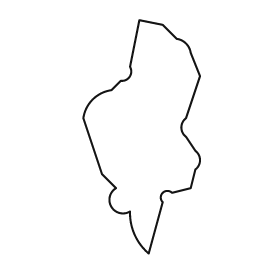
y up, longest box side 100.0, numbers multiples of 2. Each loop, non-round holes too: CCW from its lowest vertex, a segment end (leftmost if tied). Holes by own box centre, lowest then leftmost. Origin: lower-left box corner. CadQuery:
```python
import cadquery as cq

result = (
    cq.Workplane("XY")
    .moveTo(28.0, 0.0)
    .lineTo(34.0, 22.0)
    .threePointArc((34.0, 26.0), (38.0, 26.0))
    .lineTo(46.0, 28.0)
    .lineTo(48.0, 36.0)
    .threePointArc((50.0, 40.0), (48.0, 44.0))
    .lineTo(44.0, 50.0)
    .threePointArc((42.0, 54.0), (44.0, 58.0))
    .lineTo(50.0, 76.0)
    .lineTo(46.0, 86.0)
    .threePointArc((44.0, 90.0), (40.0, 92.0))
    .lineTo(34.0, 98.0)
    .lineTo(24.0, 100.0)
    .lineTo(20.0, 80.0)
    .threePointArc((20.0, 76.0), (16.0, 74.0))
    .lineTo(12.0, 70.0)
    .threePointArc((4.0, 66.0), (0.0, 58.0))
    .lineTo(8.0, 34.0)
    .lineTo(14.0, 28.0)
    .threePointArc((12.0, 20.0), (20.0, 18.0))
    .threePointArc((22.0, 8.0), (28.0, 0.0))
    .close()
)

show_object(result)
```